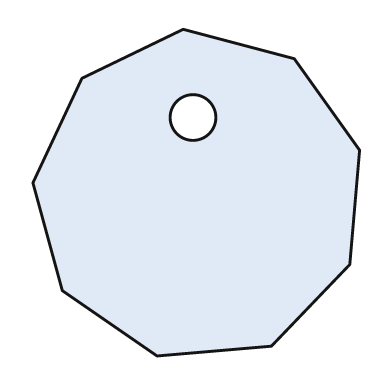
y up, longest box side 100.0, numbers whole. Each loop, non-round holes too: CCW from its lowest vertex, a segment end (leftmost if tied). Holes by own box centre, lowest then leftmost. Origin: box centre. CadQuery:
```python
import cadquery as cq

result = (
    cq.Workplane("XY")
    .moveTo(-12.0, -50.0)
    .lineTo(23.0, -47.0)
    .lineTo(47.0, -22.0)
    .lineTo(50.0, 13.0)
    .lineTo(30.0, 41.0)
    .lineTo(-4.0, 50.0)
    .lineTo(-35.0, 35.0)
    .lineTo(-50.0, 3.0)
    .lineTo(-41.0, -30.0)
    .close()
    .moveTo(-1.0, 23.0)
    .circle(7.0)
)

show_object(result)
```